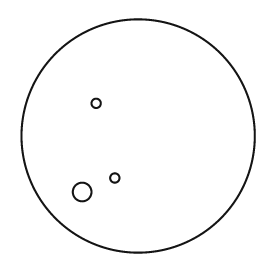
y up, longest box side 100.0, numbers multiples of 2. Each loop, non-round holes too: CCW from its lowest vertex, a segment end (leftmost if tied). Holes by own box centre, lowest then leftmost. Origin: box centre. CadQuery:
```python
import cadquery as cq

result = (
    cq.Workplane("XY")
    .moveTo(0.0, 0.0)
    .circle(50.0)
    .moveTo(-24.0, -24.0)
    .circle(4.0)
    .moveTo(-10.0, -18.0)
    .circle(2.0)
    .moveTo(-18.0, 14.0)
    .circle(2.0)
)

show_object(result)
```